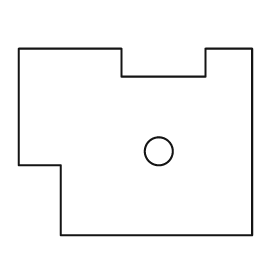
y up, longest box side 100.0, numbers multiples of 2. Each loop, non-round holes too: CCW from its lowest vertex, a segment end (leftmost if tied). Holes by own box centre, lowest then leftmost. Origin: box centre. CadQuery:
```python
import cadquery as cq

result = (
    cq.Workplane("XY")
    .moveTo(-32.0, -40.0)
    .lineTo(50.0, -40.0)
    .lineTo(50.0, 40.0)
    .lineTo(30.0, 40.0)
    .lineTo(30.0, 28.0)
    .lineTo(-6.0, 28.0)
    .lineTo(-6.0, 40.0)
    .lineTo(-50.0, 40.0)
    .lineTo(-50.0, -10.0)
    .lineTo(-32.0, -10.0)
    .close()
    .moveTo(10.0, -4.0)
    .circle(6.0)
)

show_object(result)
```